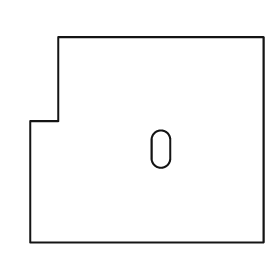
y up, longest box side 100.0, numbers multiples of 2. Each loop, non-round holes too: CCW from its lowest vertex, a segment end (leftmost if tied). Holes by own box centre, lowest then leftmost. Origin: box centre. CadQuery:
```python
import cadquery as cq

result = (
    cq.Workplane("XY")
    .moveTo(-50.0, -44.0)
    .lineTo(50.0, -44.0)
    .lineTo(50.0, 44.0)
    .lineTo(-38.0, 44.0)
    .lineTo(-38.0, 8.0)
    .lineTo(-50.0, 8.0)
    .close()
    .moveTo(2.0, -8.0)
    .threePointArc((6.0, -12.0), (10.0, -8.0))
    .lineTo(10.0, 0.0)
    .threePointArc((6.0, 4.0), (2.0, 0.0))
    .close()
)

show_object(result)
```